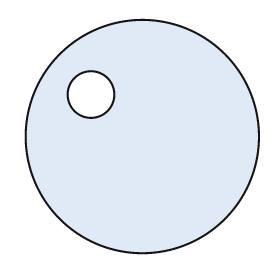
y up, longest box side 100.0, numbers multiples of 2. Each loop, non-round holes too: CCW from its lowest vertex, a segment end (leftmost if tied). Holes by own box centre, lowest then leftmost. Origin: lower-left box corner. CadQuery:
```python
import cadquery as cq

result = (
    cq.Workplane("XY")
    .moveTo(50.0, 50.0)
    .circle(50.0)
    .moveTo(28.0, 68.0)
    .circle(10.0)
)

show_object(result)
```